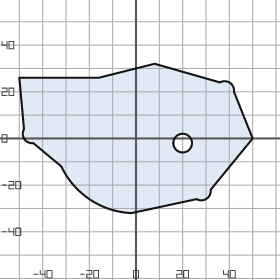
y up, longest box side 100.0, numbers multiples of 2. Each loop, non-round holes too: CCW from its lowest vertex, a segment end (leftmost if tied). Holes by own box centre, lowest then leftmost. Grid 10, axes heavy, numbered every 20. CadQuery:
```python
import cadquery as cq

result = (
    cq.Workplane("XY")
    .moveTo(-2.0, -32.0)
    .lineTo(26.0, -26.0)
    .threePointArc((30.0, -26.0), (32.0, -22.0))
    .lineTo(50.0, 0.0)
    .lineTo(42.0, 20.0)
    .threePointArc((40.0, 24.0), (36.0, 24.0))
    .lineTo(8.0, 32.0)
    .lineTo(-16.0, 26.0)
    .lineTo(-50.0, 26.0)
    .lineTo(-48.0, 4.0)
    .threePointArc((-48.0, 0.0), (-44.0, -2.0))
    .lineTo(-32.0, -12.0)
    .threePointArc((-20.0, -26.0), (-2.0, -32.0))
    .close()
    .moveTo(20.0, -2.0)
    .circle(4.0)
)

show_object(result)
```